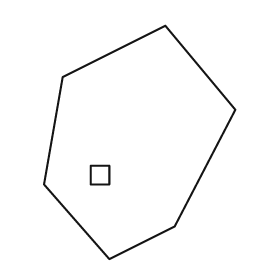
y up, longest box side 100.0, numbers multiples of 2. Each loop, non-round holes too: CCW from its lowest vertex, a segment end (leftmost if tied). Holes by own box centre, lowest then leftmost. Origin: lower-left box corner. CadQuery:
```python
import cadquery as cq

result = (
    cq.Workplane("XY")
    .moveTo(28.0, 0.0)
    .lineTo(56.0, 14.0)
    .lineTo(82.0, 64.0)
    .lineTo(52.0, 100.0)
    .lineTo(8.0, 78.0)
    .lineTo(0.0, 32.0)
    .close()
    .moveTo(20.0, 32.0)
    .lineTo(28.0, 32.0)
    .lineTo(28.0, 40.0)
    .lineTo(20.0, 40.0)
    .close()
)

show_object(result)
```